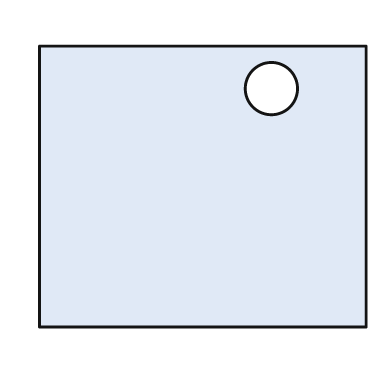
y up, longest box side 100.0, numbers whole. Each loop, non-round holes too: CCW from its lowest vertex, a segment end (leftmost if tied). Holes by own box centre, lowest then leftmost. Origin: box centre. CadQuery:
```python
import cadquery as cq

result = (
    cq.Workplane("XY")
    .moveTo(-50.0, -43.0)
    .lineTo(50.0, -43.0)
    .lineTo(50.0, 43.0)
    .lineTo(-50.0, 43.0)
    .close()
    .moveTo(21.0, 30.0)
    .circle(8.0)
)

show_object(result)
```